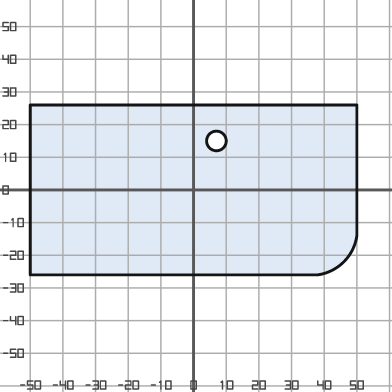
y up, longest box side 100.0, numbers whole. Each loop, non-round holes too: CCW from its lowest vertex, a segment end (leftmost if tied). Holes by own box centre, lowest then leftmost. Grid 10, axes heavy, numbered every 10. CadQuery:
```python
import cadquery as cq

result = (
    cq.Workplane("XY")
    .moveTo(-50.0, -26.0)
    .lineTo(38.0, -26.0)
    .threePointArc((46.0, -22.0), (50.0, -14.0))
    .lineTo(50.0, 26.0)
    .lineTo(-50.0, 26.0)
    .close()
    .moveTo(7.0, 15.0)
    .circle(3.0)
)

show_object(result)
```